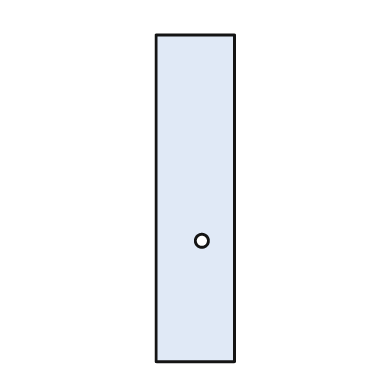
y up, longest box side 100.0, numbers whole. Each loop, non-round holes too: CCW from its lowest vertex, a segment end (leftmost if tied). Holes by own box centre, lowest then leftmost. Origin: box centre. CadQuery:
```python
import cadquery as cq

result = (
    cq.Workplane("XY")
    .moveTo(-12.0, -50.0)
    .lineTo(12.0, -50.0)
    .lineTo(12.0, 50.0)
    .lineTo(-12.0, 50.0)
    .close()
    .moveTo(2.0, -13.0)
    .circle(2.0)
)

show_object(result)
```